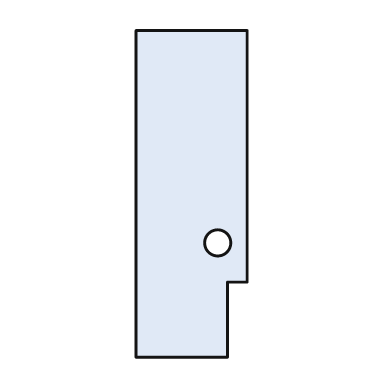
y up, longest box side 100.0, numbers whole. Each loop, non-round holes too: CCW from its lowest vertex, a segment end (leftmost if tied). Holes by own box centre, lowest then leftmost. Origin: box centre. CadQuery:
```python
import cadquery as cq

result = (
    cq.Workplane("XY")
    .moveTo(-17.0, -50.0)
    .lineTo(11.0, -50.0)
    .lineTo(11.0, -27.0)
    .lineTo(17.0, -27.0)
    .lineTo(17.0, 50.0)
    .lineTo(-17.0, 50.0)
    .close()
    .moveTo(8.0, -15.0)
    .circle(4.0)
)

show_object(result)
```